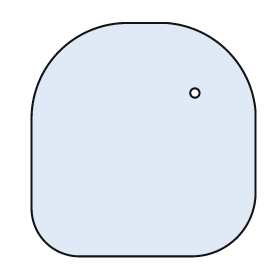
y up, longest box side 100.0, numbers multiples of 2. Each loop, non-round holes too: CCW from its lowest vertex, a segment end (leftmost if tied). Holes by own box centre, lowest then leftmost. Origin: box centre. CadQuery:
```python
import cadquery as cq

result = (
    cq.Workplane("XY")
    .moveTo(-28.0, -50.0)
    .lineTo(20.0, -50.0)
    .threePointArc((40.0, -42.0), (48.0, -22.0))
    .lineTo(48.0, 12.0)
    .threePointArc((36.0, 38.0), (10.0, 50.0))
    .lineTo(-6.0, 50.0)
    .threePointArc((-36.0, 38.0), (-48.0, 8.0))
    .lineTo(-48.0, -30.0)
    .threePointArc((-42.0, -44.0), (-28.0, -50.0))
    .close()
    .moveTo(22.0, 20.0)
    .circle(2.0)
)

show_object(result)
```